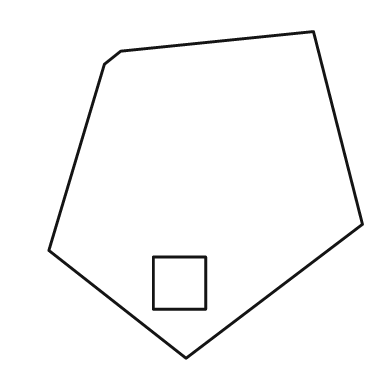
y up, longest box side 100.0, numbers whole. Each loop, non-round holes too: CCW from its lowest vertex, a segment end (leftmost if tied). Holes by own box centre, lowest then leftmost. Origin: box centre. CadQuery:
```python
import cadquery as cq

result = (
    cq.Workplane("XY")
    .moveTo(-6.0, -50.0)
    .lineTo(48.0, -9.0)
    .lineTo(33.0, 50.0)
    .lineTo(-26.0, 44.0)
    .lineTo(-31.0, 40.0)
    .lineTo(-48.0, -17.0)
    .close()
    .moveTo(-16.0, -35.0)
    .lineTo(0.0, -35.0)
    .lineTo(0.0, -19.0)
    .lineTo(-16.0, -19.0)
    .close()
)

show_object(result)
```